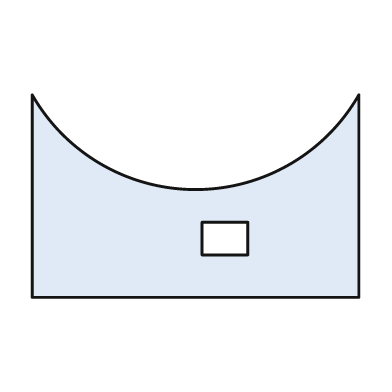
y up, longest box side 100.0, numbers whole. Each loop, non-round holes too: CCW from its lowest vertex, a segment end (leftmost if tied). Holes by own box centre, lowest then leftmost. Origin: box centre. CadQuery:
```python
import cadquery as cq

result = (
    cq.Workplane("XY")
    .moveTo(-50.0, -31.0)
    .lineTo(50.0, -31.0)
    .lineTo(50.0, 31.0)
    .threePointArc((0.0, 2.0), (-50.0, 31.0))
    .close()
    .moveTo(2.0, -18.0)
    .lineTo(16.0, -18.0)
    .lineTo(16.0, -8.0)
    .lineTo(2.0, -8.0)
    .close()
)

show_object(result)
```